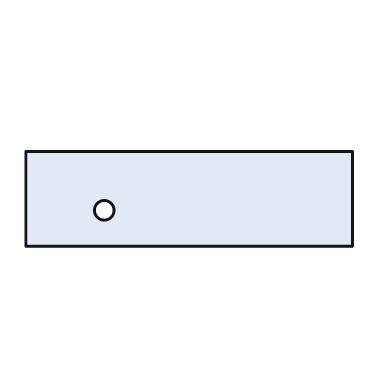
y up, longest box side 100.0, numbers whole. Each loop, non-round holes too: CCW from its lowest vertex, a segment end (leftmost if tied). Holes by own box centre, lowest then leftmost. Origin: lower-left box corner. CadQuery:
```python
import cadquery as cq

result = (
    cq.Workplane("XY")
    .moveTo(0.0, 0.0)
    .lineTo(100.0, 0.0)
    .lineTo(100.0, 29.0)
    .lineTo(0.0, 29.0)
    .close()
    .moveTo(24.0, 11.0)
    .circle(3.0)
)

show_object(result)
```